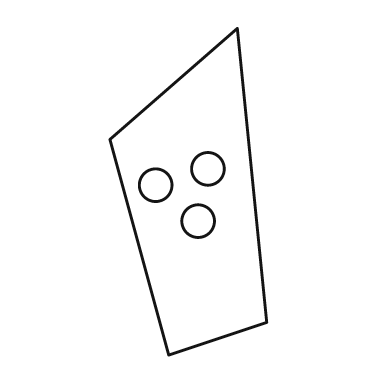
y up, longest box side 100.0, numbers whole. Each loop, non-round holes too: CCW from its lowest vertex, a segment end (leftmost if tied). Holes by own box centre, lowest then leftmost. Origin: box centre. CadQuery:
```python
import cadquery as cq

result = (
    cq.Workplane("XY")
    .moveTo(-6.0, -50.0)
    .lineTo(24.0, -40.0)
    .lineTo(15.0, 50.0)
    .lineTo(-24.0, 16.0)
    .close()
    .moveTo(3.0, -9.0)
    .circle(5.0)
    .moveTo(-10.0, 2.0)
    .circle(5.0)
    .moveTo(6.0, 7.0)
    .circle(5.0)
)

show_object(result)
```